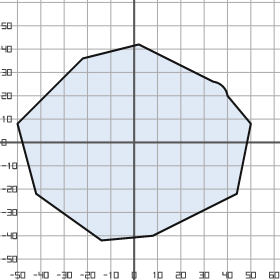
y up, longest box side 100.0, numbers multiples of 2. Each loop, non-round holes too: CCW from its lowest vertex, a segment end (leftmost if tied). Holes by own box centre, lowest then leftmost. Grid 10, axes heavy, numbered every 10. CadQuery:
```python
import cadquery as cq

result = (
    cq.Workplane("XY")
    .moveTo(-14.0, -42.0)
    .lineTo(8.0, -40.0)
    .lineTo(44.0, -22.0)
    .lineTo(50.0, 8.0)
    .lineTo(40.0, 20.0)
    .threePointArc((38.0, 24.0), (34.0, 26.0))
    .lineTo(2.0, 42.0)
    .lineTo(-22.0, 36.0)
    .lineTo(-50.0, 8.0)
    .lineTo(-42.0, -22.0)
    .close()
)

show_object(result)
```